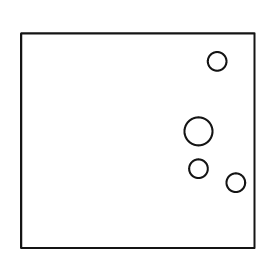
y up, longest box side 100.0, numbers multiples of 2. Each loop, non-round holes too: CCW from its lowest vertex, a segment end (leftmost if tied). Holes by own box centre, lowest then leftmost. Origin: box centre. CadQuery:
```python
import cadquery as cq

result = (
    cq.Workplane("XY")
    .moveTo(-50.0, -46.0)
    .lineTo(50.0, -46.0)
    .lineTo(50.0, 46.0)
    .lineTo(-50.0, 46.0)
    .close()
    .moveTo(42.0, -18.0)
    .circle(4.0)
    .moveTo(26.0, -12.0)
    .circle(4.0)
    .moveTo(26.0, 4.0)
    .circle(6.0)
    .moveTo(34.0, 34.0)
    .circle(4.0)
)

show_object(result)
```